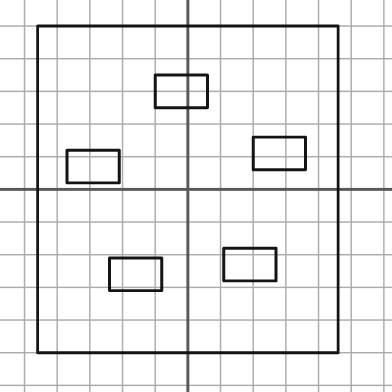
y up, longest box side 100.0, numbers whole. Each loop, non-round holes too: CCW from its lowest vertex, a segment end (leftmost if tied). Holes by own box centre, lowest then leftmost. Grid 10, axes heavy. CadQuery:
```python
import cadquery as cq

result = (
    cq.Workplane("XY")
    .moveTo(-46.0, -50.0)
    .lineTo(46.0, -50.0)
    .lineTo(46.0, 50.0)
    .lineTo(-46.0, 50.0)
    .close()
    .moveTo(-24.0, -31.0)
    .lineTo(-8.0, -31.0)
    .lineTo(-8.0, -21.0)
    .lineTo(-24.0, -21.0)
    .close()
    .moveTo(11.0, -28.0)
    .lineTo(27.0, -28.0)
    .lineTo(27.0, -18.0)
    .lineTo(11.0, -18.0)
    .close()
    .moveTo(-37.0, 2.0)
    .lineTo(-21.0, 2.0)
    .lineTo(-21.0, 12.0)
    .lineTo(-37.0, 12.0)
    .close()
    .moveTo(20.0, 6.0)
    .lineTo(36.0, 6.0)
    .lineTo(36.0, 16.0)
    .lineTo(20.0, 16.0)
    .close()
    .moveTo(-10.0, 25.0)
    .lineTo(6.0, 25.0)
    .lineTo(6.0, 35.0)
    .lineTo(-10.0, 35.0)
    .close()
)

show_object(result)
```